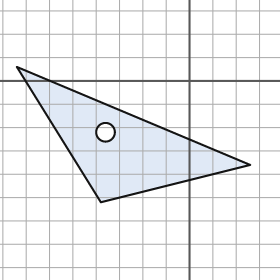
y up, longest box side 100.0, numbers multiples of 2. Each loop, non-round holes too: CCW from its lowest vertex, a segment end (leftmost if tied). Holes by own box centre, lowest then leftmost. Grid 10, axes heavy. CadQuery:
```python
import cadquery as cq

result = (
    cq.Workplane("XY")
    .moveTo(-38.0, -52.0)
    .lineTo(26.0, -36.0)
    .lineTo(-74.0, 6.0)
    .close()
    .moveTo(-36.0, -22.0)
    .circle(4.0)
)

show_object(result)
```